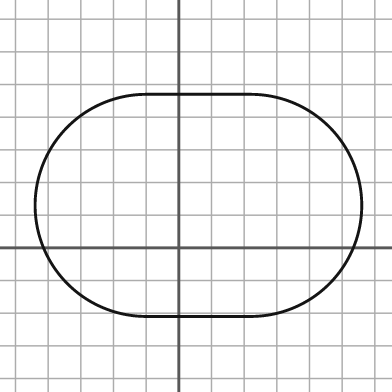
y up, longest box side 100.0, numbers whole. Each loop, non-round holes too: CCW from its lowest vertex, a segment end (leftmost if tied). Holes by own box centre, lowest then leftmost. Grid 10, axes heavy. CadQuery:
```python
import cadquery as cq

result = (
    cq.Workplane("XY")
    .moveTo(-10.0, -21.0)
    .lineTo(22.0, -21.0)
    .threePointArc((56.0, 13.0), (22.0, 47.0))
    .lineTo(-10.0, 47.0)
    .threePointArc((-44.0, 13.0), (-10.0, -21.0))
    .close()
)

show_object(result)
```